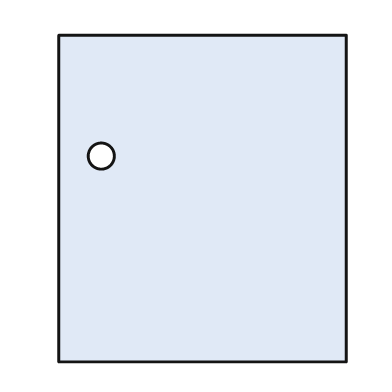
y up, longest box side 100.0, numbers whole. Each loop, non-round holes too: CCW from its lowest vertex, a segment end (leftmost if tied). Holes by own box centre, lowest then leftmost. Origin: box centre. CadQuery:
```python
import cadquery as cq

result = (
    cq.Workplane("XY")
    .moveTo(-44.0, -50.0)
    .lineTo(44.0, -50.0)
    .lineTo(44.0, 50.0)
    .lineTo(-44.0, 50.0)
    .close()
    .moveTo(-31.0, 13.0)
    .circle(4.0)
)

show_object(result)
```